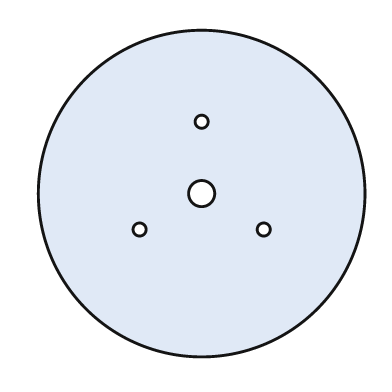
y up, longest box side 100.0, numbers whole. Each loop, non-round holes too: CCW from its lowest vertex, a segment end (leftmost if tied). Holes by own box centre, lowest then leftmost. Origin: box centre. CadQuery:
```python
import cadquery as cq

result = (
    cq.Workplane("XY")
    .moveTo(0.0, 0.0)
    .circle(50.0)
    .moveTo(-19.0, -11.0)
    .circle(2.0)
    .moveTo(19.0, -11.0)
    .circle(2.0)
    .moveTo(0.0, 0.0)
    .circle(4.0)
    .moveTo(0.0, 22.0)
    .circle(2.0)
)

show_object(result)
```